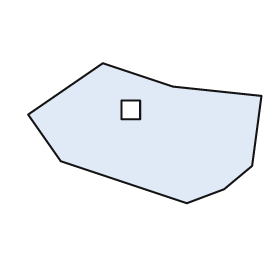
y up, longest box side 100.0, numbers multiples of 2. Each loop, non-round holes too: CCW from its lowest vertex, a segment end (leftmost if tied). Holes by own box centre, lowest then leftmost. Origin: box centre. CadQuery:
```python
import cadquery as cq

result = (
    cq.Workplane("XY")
    .moveTo(18.0, -30.0)
    .lineTo(34.0, -24.0)
    .lineTo(46.0, -14.0)
    .lineTo(50.0, 16.0)
    .lineTo(12.0, 20.0)
    .lineTo(-18.0, 30.0)
    .lineTo(-50.0, 8.0)
    .lineTo(-36.0, -12.0)
    .close()
    .moveTo(-10.0, 6.0)
    .lineTo(-2.0, 6.0)
    .lineTo(-2.0, 14.0)
    .lineTo(-10.0, 14.0)
    .close()
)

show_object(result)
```